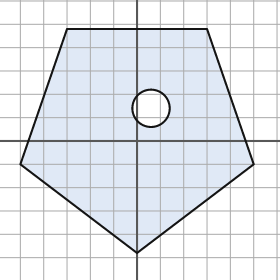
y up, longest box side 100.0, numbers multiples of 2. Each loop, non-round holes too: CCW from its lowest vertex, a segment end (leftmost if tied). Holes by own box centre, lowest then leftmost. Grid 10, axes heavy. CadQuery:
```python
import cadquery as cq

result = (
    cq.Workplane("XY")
    .moveTo(0.0, -48.0)
    .lineTo(50.0, -10.0)
    .lineTo(30.0, 48.0)
    .lineTo(-30.0, 48.0)
    .lineTo(-50.0, -10.0)
    .close()
    .moveTo(6.0, 14.0)
    .circle(8.0)
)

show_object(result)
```